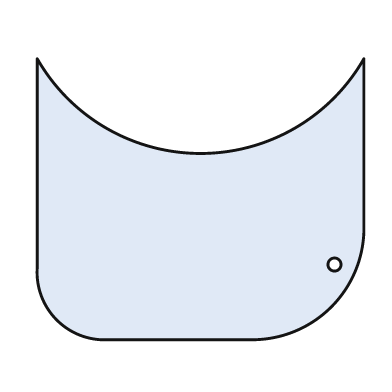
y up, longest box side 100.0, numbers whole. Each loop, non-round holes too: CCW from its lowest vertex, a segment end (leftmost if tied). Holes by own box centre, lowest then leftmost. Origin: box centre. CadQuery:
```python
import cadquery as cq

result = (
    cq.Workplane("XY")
    .moveTo(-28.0, -43.0)
    .lineTo(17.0, -43.0)
    .threePointArc((40.0, -33.0), (50.0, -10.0))
    .lineTo(50.0, 43.0)
    .threePointArc((0.0, 14.0), (-50.0, 43.0))
    .lineTo(-50.0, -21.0)
    .threePointArc((-44.0, -37.0), (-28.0, -43.0))
    .close()
    .moveTo(41.0, -20.0)
    .circle(2.0)
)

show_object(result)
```